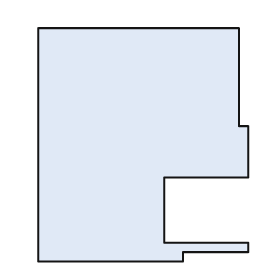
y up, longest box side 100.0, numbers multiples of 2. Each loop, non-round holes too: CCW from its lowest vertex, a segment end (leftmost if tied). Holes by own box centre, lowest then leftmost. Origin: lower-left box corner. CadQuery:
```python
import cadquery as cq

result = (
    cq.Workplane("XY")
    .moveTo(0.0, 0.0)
    .lineTo(62.0, 0.0)
    .lineTo(62.0, 4.0)
    .lineTo(90.0, 4.0)
    .lineTo(90.0, 8.0)
    .lineTo(54.0, 8.0)
    .lineTo(54.0, 36.0)
    .lineTo(90.0, 36.0)
    .lineTo(90.0, 58.0)
    .lineTo(86.0, 58.0)
    .lineTo(86.0, 100.0)
    .lineTo(0.0, 100.0)
    .close()
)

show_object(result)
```